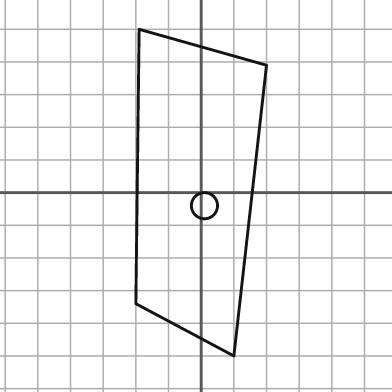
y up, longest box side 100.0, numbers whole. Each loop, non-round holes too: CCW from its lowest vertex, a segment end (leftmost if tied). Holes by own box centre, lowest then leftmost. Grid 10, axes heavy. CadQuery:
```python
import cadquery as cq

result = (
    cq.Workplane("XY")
    .moveTo(10.0, -50.0)
    .lineTo(20.0, 39.0)
    .lineTo(-19.0, 50.0)
    .lineTo(-20.0, -34.0)
    .close()
    .moveTo(1.0, -4.0)
    .circle(4.0)
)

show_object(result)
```